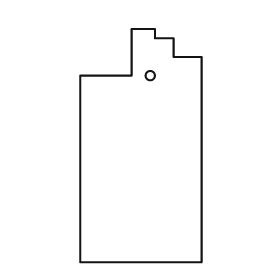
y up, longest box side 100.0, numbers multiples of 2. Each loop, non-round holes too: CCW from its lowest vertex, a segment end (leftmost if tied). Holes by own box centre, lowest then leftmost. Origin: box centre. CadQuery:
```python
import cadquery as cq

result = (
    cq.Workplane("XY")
    .moveTo(-26.0, -50.0)
    .lineTo(26.0, -50.0)
    .lineTo(26.0, 38.0)
    .lineTo(14.0, 38.0)
    .lineTo(14.0, 46.0)
    .lineTo(6.0, 46.0)
    .lineTo(6.0, 50.0)
    .lineTo(-4.0, 50.0)
    .lineTo(-4.0, 30.0)
    .lineTo(-26.0, 30.0)
    .close()
    .moveTo(4.0, 30.0)
    .circle(2.0)
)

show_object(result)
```